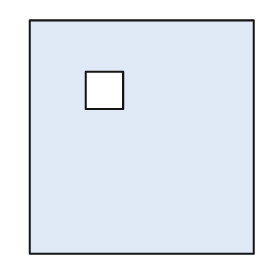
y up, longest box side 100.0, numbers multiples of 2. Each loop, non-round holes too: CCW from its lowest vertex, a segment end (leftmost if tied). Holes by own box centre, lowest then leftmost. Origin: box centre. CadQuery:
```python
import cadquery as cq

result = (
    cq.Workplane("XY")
    .moveTo(-48.0, -50.0)
    .lineTo(48.0, -50.0)
    .lineTo(48.0, 50.0)
    .lineTo(-48.0, 50.0)
    .close()
    .moveTo(-24.0, 12.0)
    .lineTo(-8.0, 12.0)
    .lineTo(-8.0, 28.0)
    .lineTo(-24.0, 28.0)
    .close()
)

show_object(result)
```